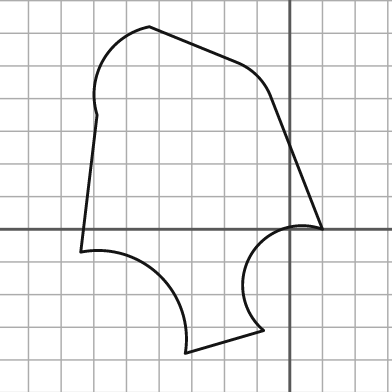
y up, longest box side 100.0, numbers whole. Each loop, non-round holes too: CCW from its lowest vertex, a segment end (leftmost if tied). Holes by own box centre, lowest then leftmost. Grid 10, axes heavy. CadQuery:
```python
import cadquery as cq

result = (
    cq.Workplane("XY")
    .moveTo(-32.0, -38.0)
    .lineTo(-8.0, -31.0)
    .threePointArc((-12.0, -8.0), (10.0, 0.0))
    .lineTo(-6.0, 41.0)
    .threePointArc((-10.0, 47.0), (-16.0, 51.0))
    .lineTo(-43.0, 62.0)
    .threePointArc((-57.0, 52.0), (-59.0, 35.0))
    .lineTo(-64.0, -7.0)
    .threePointArc((-40.0, -14.0), (-32.0, -38.0))
    .close()
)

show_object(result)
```